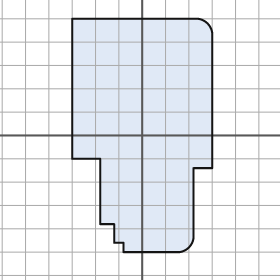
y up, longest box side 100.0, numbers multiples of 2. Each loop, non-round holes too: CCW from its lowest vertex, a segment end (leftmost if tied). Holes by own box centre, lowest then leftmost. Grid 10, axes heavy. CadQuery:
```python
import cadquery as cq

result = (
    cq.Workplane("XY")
    .moveTo(-8.0, -50.0)
    .lineTo(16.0, -50.0)
    .threePointArc((20.0, -48.0), (22.0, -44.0))
    .lineTo(22.0, -14.0)
    .lineTo(30.0, -14.0)
    .lineTo(30.0, 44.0)
    .threePointArc((28.0, 48.0), (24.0, 50.0))
    .lineTo(-30.0, 50.0)
    .lineTo(-30.0, -10.0)
    .lineTo(-18.0, -10.0)
    .lineTo(-18.0, -38.0)
    .lineTo(-12.0, -38.0)
    .lineTo(-12.0, -46.0)
    .lineTo(-8.0, -46.0)
    .close()
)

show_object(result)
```